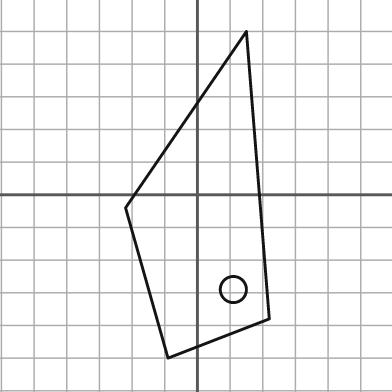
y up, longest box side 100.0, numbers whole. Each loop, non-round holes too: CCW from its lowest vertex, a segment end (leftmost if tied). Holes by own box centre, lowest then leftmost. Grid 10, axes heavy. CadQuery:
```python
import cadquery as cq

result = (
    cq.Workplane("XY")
    .moveTo(-9.0, -50.0)
    .lineTo(22.0, -38.0)
    .lineTo(15.0, 50.0)
    .lineTo(-22.0, -4.0)
    .close()
    .moveTo(11.0, -29.0)
    .circle(4.0)
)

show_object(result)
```